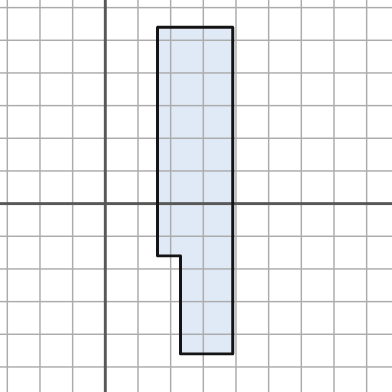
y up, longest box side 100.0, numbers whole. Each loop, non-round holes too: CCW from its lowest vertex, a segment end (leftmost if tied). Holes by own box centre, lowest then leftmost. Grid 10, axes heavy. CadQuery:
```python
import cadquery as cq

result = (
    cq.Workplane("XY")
    .moveTo(23.0, -46.0)
    .lineTo(39.0, -46.0)
    .lineTo(39.0, 54.0)
    .lineTo(16.0, 54.0)
    .lineTo(16.0, -16.0)
    .lineTo(23.0, -16.0)
    .close()
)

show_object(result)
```